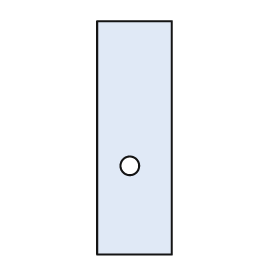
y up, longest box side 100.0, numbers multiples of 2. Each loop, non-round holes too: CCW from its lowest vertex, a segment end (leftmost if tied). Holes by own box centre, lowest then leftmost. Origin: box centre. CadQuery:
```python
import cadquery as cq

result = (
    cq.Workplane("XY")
    .moveTo(-16.0, -50.0)
    .lineTo(16.0, -50.0)
    .lineTo(16.0, 50.0)
    .lineTo(-16.0, 50.0)
    .close()
    .moveTo(-2.0, -12.0)
    .circle(4.0)
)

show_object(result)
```